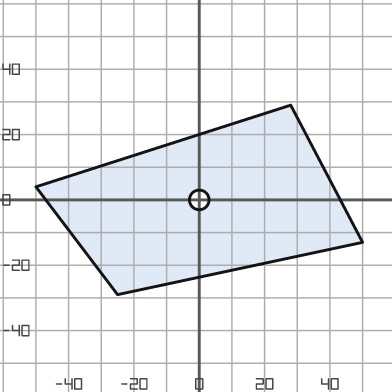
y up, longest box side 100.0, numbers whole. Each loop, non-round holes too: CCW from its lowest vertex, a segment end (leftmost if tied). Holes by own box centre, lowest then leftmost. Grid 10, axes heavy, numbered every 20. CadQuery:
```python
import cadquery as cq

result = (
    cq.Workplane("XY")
    .moveTo(-25.0, -29.0)
    .lineTo(50.0, -13.0)
    .lineTo(28.0, 29.0)
    .lineTo(-50.0, 4.0)
    .close()
    .moveTo(0.0, 0.0)
    .circle(3.0)
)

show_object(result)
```